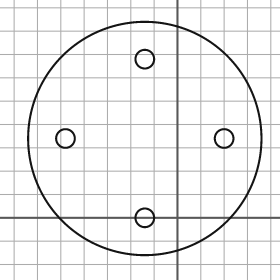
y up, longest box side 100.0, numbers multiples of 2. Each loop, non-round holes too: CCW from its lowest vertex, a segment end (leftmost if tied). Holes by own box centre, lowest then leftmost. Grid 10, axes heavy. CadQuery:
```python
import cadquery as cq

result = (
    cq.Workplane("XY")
    .moveTo(-14.0, 34.0)
    .circle(50.0)
    .moveTo(-14.0, 0.0)
    .circle(4.0)
    .moveTo(-48.0, 34.0)
    .circle(4.0)
    .moveTo(20.0, 34.0)
    .circle(4.0)
    .moveTo(-14.0, 68.0)
    .circle(4.0)
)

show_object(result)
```